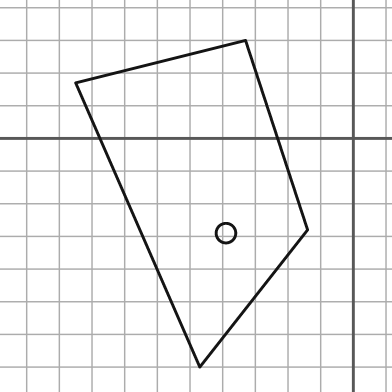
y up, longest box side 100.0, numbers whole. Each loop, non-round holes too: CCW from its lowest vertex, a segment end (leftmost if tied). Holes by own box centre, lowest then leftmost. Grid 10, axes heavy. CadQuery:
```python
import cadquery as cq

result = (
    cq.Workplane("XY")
    .moveTo(-47.0, -70.0)
    .lineTo(-14.0, -28.0)
    .lineTo(-33.0, 30.0)
    .lineTo(-85.0, 17.0)
    .close()
    .moveTo(-39.0, -29.0)
    .circle(3.0)
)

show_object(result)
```